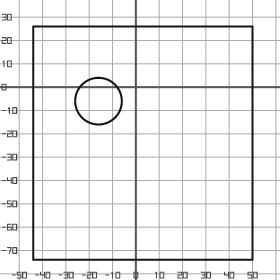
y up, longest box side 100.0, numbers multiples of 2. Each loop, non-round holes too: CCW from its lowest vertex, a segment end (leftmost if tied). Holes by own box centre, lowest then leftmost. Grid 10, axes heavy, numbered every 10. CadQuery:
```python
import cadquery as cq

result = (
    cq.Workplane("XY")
    .moveTo(-44.0, -74.0)
    .lineTo(50.0, -74.0)
    .lineTo(50.0, 26.0)
    .lineTo(-44.0, 26.0)
    .close()
    .moveTo(-16.0, -6.0)
    .circle(10.0)
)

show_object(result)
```